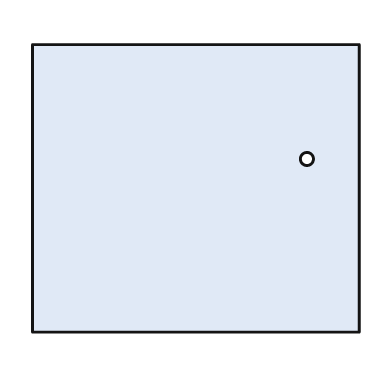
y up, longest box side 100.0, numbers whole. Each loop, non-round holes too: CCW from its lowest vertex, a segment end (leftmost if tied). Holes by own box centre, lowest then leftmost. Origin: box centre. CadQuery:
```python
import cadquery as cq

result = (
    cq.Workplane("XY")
    .moveTo(-50.0, -44.0)
    .lineTo(50.0, -44.0)
    .lineTo(50.0, 44.0)
    .lineTo(-50.0, 44.0)
    .close()
    .moveTo(34.0, 9.0)
    .circle(2.0)
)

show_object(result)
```